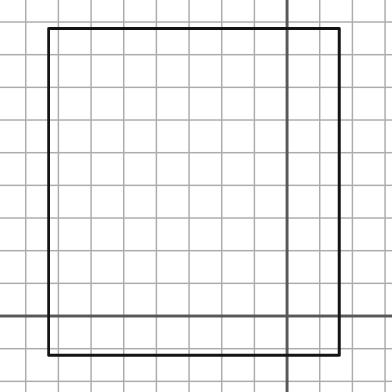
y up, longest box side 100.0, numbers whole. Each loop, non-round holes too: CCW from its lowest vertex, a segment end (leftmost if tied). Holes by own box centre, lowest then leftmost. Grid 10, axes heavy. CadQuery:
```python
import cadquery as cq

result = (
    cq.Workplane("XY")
    .moveTo(-73.0, -12.0)
    .lineTo(16.0, -12.0)
    .lineTo(16.0, 88.0)
    .lineTo(-73.0, 88.0)
    .close()
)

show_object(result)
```